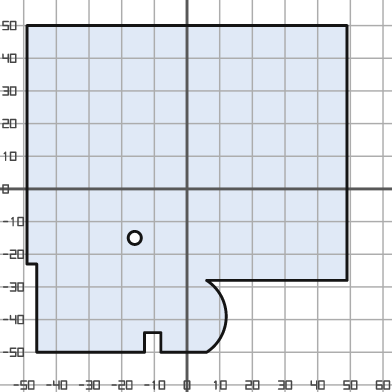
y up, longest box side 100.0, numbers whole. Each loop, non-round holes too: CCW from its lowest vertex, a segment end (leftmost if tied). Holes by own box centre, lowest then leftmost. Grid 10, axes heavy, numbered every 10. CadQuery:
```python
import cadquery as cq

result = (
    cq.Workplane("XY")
    .moveTo(-46.0, -50.0)
    .lineTo(-13.0, -50.0)
    .lineTo(-13.0, -44.0)
    .lineTo(-8.0, -44.0)
    .lineTo(-8.0, -50.0)
    .lineTo(6.0, -50.0)
    .threePointArc((12.0, -39.0), (6.0, -28.0))
    .lineTo(49.0, -28.0)
    .lineTo(49.0, 50.0)
    .lineTo(-49.0, 50.0)
    .lineTo(-49.0, -23.0)
    .lineTo(-46.0, -23.0)
    .close()
    .moveTo(-16.0, -15.0)
    .circle(2.0)
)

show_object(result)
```